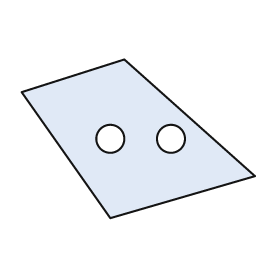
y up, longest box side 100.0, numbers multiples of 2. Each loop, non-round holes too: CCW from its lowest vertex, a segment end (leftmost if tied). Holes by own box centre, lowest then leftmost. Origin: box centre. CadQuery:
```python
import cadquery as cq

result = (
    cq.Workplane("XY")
    .moveTo(-12.0, -34.0)
    .lineTo(50.0, -16.0)
    .lineTo(-6.0, 34.0)
    .lineTo(-50.0, 20.0)
    .close()
    .moveTo(-12.0, 0.0)
    .circle(6.0)
    .moveTo(14.0, 0.0)
    .circle(6.0)
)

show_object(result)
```